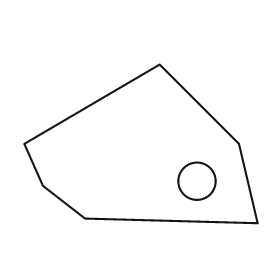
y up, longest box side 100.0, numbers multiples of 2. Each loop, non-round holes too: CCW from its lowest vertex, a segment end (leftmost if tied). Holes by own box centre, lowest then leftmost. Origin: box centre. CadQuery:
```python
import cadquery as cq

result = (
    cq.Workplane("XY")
    .moveTo(50.0, -34.0)
    .lineTo(42.0, 0.0)
    .lineTo(8.0, 34.0)
    .lineTo(-50.0, 0.0)
    .lineTo(-42.0, -18.0)
    .lineTo(-24.0, -32.0)
    .close()
    .moveTo(24.0, -16.0)
    .circle(8.0)
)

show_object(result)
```